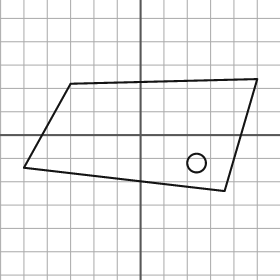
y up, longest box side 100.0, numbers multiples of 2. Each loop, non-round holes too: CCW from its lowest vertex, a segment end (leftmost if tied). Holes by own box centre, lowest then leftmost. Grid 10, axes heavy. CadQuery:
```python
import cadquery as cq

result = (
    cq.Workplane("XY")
    .moveTo(36.0, -24.0)
    .lineTo(50.0, 24.0)
    .lineTo(-30.0, 22.0)
    .lineTo(-50.0, -14.0)
    .close()
    .moveTo(24.0, -12.0)
    .circle(4.0)
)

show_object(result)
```